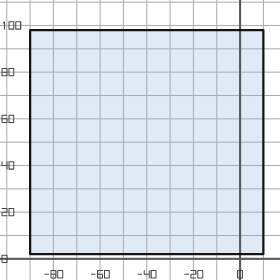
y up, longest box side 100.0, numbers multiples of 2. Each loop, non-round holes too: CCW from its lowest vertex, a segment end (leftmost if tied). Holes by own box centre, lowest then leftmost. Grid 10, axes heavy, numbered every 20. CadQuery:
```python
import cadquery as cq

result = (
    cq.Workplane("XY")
    .moveTo(-90.0, 2.0)
    .lineTo(10.0, 2.0)
    .lineTo(10.0, 98.0)
    .lineTo(-90.0, 98.0)
    .close()
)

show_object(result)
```